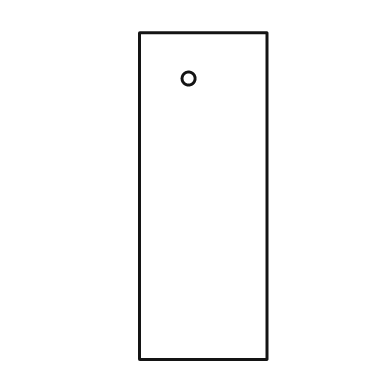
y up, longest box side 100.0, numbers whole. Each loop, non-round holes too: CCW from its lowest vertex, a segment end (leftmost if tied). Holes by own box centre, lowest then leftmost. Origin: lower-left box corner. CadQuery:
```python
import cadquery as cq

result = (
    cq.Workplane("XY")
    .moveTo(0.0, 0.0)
    .lineTo(39.0, 0.0)
    .lineTo(39.0, 100.0)
    .lineTo(0.0, 100.0)
    .close()
    .moveTo(15.0, 86.0)
    .circle(2.0)
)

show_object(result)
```